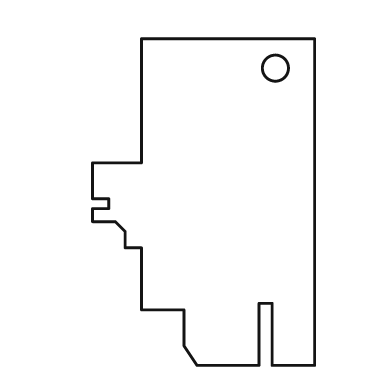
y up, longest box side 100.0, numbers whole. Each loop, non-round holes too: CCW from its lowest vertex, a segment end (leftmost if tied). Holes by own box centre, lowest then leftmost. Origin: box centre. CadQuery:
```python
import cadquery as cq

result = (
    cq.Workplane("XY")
    .moveTo(-2.0, -50.0)
    .lineTo(17.0, -50.0)
    .lineTo(17.0, -31.0)
    .lineTo(21.0, -31.0)
    .lineTo(21.0, -50.0)
    .lineTo(34.0, -50.0)
    .lineTo(34.0, 50.0)
    .lineTo(-19.0, 50.0)
    .lineTo(-19.0, 12.0)
    .lineTo(-34.0, 12.0)
    .lineTo(-34.0, 1.0)
    .lineTo(-29.0, 1.0)
    .lineTo(-29.0, -2.0)
    .lineTo(-34.0, -2.0)
    .lineTo(-34.0, -6.0)
    .lineTo(-27.0, -6.0)
    .lineTo(-24.0, -9.0)
    .lineTo(-24.0, -14.0)
    .lineTo(-19.0, -14.0)
    .lineTo(-19.0, -33.0)
    .lineTo(-6.0, -33.0)
    .lineTo(-6.0, -44.0)
    .close()
    .moveTo(22.0, 41.0)
    .circle(4.0)
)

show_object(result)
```